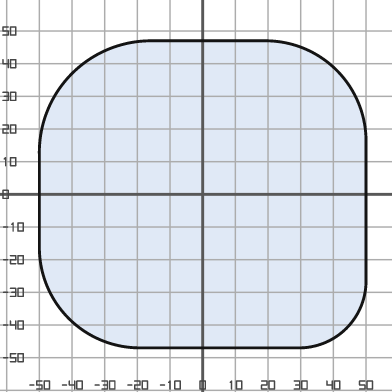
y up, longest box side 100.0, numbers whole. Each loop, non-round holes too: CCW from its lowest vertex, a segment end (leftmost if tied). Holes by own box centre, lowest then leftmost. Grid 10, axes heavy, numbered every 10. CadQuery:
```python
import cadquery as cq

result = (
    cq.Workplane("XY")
    .moveTo(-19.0, -47.0)
    .lineTo(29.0, -47.0)
    .threePointArc((44.0, -41.0), (50.0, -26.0))
    .lineTo(50.0, 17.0)
    .threePointArc((41.0, 38.0), (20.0, 47.0))
    .lineTo(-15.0, 47.0)
    .threePointArc((-40.0, 37.0), (-50.0, 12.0))
    .lineTo(-50.0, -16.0)
    .threePointArc((-41.0, -38.0), (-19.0, -47.0))
    .close()
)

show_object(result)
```